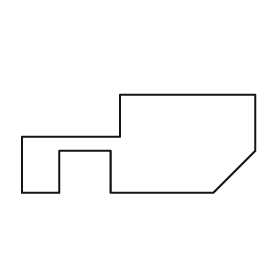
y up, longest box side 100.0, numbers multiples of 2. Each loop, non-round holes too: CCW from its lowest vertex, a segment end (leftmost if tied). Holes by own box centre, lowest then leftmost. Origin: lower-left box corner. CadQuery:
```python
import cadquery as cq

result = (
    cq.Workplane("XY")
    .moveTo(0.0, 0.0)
    .lineTo(16.0, 0.0)
    .lineTo(16.0, 18.0)
    .lineTo(38.0, 18.0)
    .lineTo(38.0, 0.0)
    .lineTo(82.0, 0.0)
    .lineTo(100.0, 18.0)
    .lineTo(100.0, 42.0)
    .lineTo(42.0, 42.0)
    .lineTo(42.0, 24.0)
    .lineTo(0.0, 24.0)
    .close()
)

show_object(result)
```